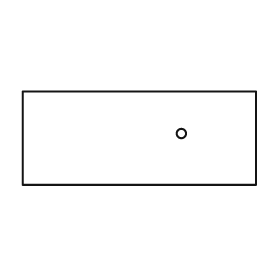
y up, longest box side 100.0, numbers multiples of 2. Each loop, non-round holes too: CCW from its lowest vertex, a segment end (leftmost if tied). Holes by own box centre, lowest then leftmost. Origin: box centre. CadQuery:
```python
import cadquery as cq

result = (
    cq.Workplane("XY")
    .moveTo(-50.0, -20.0)
    .lineTo(50.0, -20.0)
    .lineTo(50.0, 20.0)
    .lineTo(-50.0, 20.0)
    .close()
    .moveTo(18.0, 2.0)
    .circle(2.0)
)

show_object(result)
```